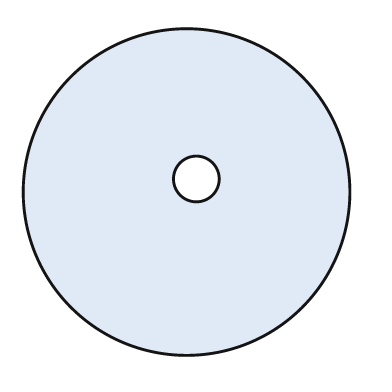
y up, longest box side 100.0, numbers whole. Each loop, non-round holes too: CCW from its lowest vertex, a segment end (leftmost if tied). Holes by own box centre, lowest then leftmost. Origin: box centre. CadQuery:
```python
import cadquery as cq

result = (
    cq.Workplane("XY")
    .moveTo(0.0, 0.0)
    .circle(50.0)
    .moveTo(3.0, 4.0)
    .circle(7.0)
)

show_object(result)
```